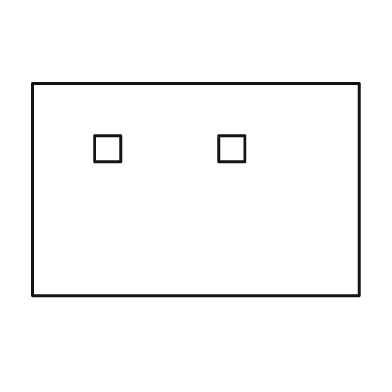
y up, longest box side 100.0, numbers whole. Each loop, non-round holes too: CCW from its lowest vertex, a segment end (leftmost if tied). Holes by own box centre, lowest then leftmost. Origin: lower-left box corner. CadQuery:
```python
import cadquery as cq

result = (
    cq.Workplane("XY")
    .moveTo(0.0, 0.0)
    .lineTo(100.0, 0.0)
    .lineTo(100.0, 65.0)
    .lineTo(0.0, 65.0)
    .close()
    .moveTo(19.0, 41.0)
    .lineTo(27.0, 41.0)
    .lineTo(27.0, 49.0)
    .lineTo(19.0, 49.0)
    .close()
    .moveTo(57.0, 41.0)
    .lineTo(65.0, 41.0)
    .lineTo(65.0, 49.0)
    .lineTo(57.0, 49.0)
    .close()
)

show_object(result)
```